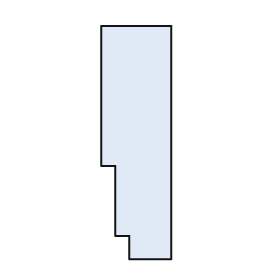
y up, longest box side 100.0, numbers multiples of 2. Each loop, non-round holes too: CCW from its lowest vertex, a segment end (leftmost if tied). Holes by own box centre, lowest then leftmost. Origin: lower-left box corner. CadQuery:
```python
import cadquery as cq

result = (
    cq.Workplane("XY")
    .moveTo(12.0, 0.0)
    .lineTo(30.0, 0.0)
    .lineTo(30.0, 100.0)
    .lineTo(0.0, 100.0)
    .lineTo(0.0, 40.0)
    .lineTo(6.0, 40.0)
    .lineTo(6.0, 10.0)
    .lineTo(12.0, 10.0)
    .close()
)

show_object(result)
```